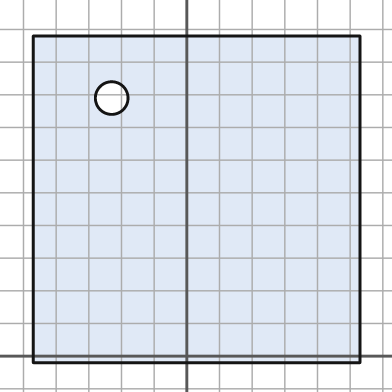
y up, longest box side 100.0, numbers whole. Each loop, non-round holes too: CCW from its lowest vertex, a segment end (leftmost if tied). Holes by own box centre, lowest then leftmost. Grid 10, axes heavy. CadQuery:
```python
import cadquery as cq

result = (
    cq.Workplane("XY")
    .moveTo(-47.0, -2.0)
    .lineTo(53.0, -2.0)
    .lineTo(53.0, 98.0)
    .lineTo(-47.0, 98.0)
    .close()
    .moveTo(-23.0, 79.0)
    .circle(5.0)
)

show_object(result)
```